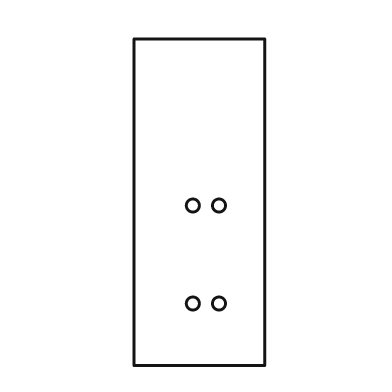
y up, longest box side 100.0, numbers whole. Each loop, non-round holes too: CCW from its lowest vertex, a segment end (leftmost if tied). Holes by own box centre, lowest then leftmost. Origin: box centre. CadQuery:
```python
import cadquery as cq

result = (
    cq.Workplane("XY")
    .moveTo(-20.0, -50.0)
    .lineTo(20.0, -50.0)
    .lineTo(20.0, 50.0)
    .lineTo(-20.0, 50.0)
    .close()
    .moveTo(-2.0, -31.0)
    .circle(2.0)
    .moveTo(6.0, -31.0)
    .circle(2.0)
    .moveTo(-2.0, -1.0)
    .circle(2.0)
    .moveTo(6.0, -1.0)
    .circle(2.0)
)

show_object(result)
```